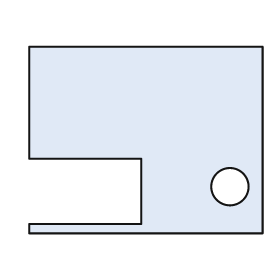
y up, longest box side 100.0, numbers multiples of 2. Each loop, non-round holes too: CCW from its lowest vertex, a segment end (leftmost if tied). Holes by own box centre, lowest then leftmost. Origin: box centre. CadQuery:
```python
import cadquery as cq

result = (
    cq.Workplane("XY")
    .moveTo(-50.0, -40.0)
    .lineTo(50.0, -40.0)
    .lineTo(50.0, 40.0)
    .lineTo(-50.0, 40.0)
    .lineTo(-50.0, -8.0)
    .lineTo(-2.0, -8.0)
    .lineTo(-2.0, -36.0)
    .lineTo(-50.0, -36.0)
    .close()
    .moveTo(36.0, -20.0)
    .circle(8.0)
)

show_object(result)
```